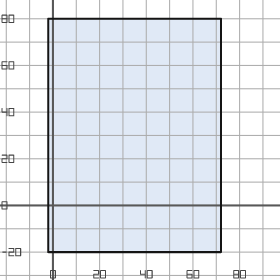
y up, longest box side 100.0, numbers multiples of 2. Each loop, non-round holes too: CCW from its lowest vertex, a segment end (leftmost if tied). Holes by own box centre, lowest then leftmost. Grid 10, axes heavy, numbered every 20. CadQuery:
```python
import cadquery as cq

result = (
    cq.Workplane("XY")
    .moveTo(-2.0, -20.0)
    .lineTo(72.0, -20.0)
    .lineTo(72.0, 80.0)
    .lineTo(-2.0, 80.0)
    .close()
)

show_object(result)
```